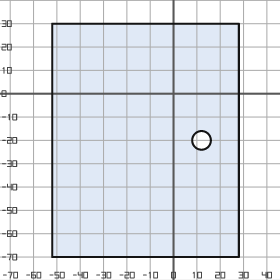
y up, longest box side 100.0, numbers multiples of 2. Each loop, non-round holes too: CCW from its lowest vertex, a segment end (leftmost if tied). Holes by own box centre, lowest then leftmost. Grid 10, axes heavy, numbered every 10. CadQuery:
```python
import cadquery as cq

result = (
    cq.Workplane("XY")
    .moveTo(-52.0, -70.0)
    .lineTo(28.0, -70.0)
    .lineTo(28.0, 30.0)
    .lineTo(-52.0, 30.0)
    .close()
    .moveTo(12.0, -20.0)
    .circle(4.0)
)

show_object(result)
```